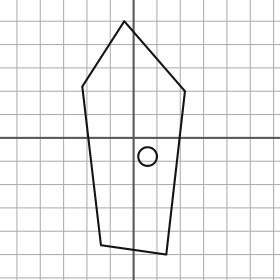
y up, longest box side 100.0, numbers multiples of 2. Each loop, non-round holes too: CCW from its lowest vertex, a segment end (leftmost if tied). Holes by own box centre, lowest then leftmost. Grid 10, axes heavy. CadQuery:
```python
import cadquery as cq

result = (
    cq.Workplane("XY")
    .moveTo(14.0, -50.0)
    .lineTo(22.0, 20.0)
    .lineTo(-4.0, 50.0)
    .lineTo(-22.0, 22.0)
    .lineTo(-14.0, -46.0)
    .close()
    .moveTo(6.0, -8.0)
    .circle(4.0)
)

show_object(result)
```